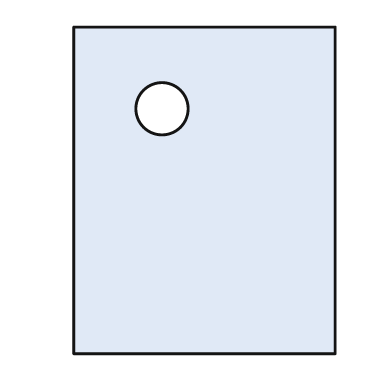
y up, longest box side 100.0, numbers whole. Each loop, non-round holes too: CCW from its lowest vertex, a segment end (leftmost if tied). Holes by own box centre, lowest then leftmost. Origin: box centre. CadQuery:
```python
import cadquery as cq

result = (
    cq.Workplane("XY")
    .moveTo(-40.0, -50.0)
    .lineTo(40.0, -50.0)
    .lineTo(40.0, 50.0)
    .lineTo(-40.0, 50.0)
    .close()
    .moveTo(-13.0, 25.0)
    .circle(8.0)
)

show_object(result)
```